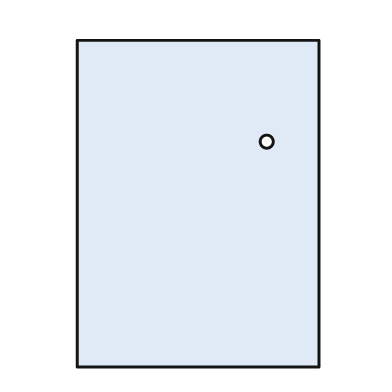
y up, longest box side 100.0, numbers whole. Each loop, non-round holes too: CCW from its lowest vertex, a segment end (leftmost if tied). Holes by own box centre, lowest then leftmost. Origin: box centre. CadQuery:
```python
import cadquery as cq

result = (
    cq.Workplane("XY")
    .moveTo(-37.0, -50.0)
    .lineTo(37.0, -50.0)
    .lineTo(37.0, 50.0)
    .lineTo(-37.0, 50.0)
    .close()
    .moveTo(21.0, 19.0)
    .circle(2.0)
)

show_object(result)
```